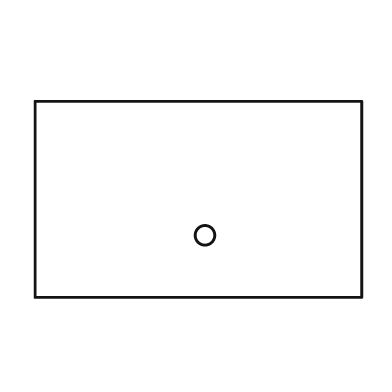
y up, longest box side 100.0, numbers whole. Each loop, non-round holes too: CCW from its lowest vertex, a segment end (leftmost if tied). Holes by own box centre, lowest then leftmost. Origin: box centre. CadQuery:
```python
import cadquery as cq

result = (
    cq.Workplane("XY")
    .moveTo(-50.0, -30.0)
    .lineTo(50.0, -30.0)
    .lineTo(50.0, 30.0)
    .lineTo(-50.0, 30.0)
    .close()
    .moveTo(2.0, -11.0)
    .circle(3.0)
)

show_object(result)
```